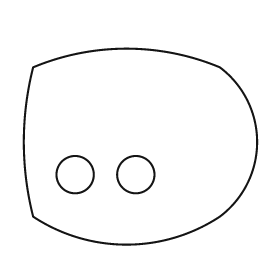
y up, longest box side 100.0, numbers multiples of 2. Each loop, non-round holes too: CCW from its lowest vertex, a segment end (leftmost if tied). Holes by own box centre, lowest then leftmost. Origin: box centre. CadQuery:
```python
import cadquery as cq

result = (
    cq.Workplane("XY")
    .moveTo(-46.0, -30.0)
    .threePointArc((-6.0, -42.0), (34.0, -30.0))
    .threePointArc((50.0, 2.0), (34.0, 34.0))
    .threePointArc((-6.0, 42.0), (-46.0, 34.0))
    .threePointArc((-50.0, 2.0), (-46.0, -30.0))
    .close()
    .moveTo(-28.0, -12.0)
    .circle(8.0)
    .moveTo(-2.0, -12.0)
    .circle(8.0)
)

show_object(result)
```